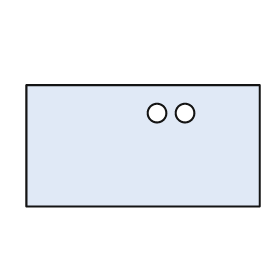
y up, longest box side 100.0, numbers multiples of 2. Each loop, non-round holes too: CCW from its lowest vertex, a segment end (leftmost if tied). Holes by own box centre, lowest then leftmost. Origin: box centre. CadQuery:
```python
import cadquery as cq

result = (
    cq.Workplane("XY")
    .moveTo(-50.0, -26.0)
    .lineTo(50.0, -26.0)
    .lineTo(50.0, 26.0)
    .lineTo(-50.0, 26.0)
    .close()
    .moveTo(6.0, 14.0)
    .circle(4.0)
    .moveTo(18.0, 14.0)
    .circle(4.0)
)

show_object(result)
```